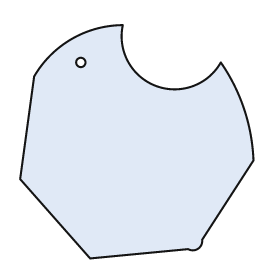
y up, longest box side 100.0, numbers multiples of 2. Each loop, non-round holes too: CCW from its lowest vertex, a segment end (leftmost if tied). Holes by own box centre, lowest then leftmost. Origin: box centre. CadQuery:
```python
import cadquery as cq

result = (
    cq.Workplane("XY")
    .moveTo(-20.0, -50.0)
    .lineTo(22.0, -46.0)
    .threePointArc((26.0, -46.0), (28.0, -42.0))
    .lineTo(50.0, -8.0)
    .threePointArc((46.0, 14.0), (36.0, 34.0))
    .threePointArc((8.0, 24.0), (-6.0, 50.0))
    .threePointArc((-28.0, 44.0), (-44.0, 28.0))
    .lineTo(-50.0, -16.0)
    .close()
    .moveTo(-24.0, 34.0)
    .circle(2.0)
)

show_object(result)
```